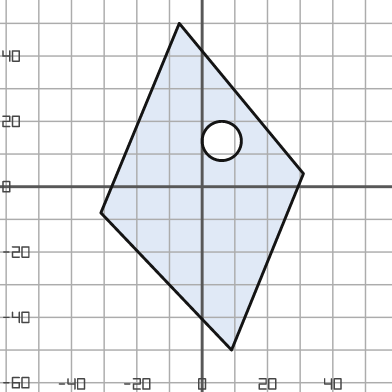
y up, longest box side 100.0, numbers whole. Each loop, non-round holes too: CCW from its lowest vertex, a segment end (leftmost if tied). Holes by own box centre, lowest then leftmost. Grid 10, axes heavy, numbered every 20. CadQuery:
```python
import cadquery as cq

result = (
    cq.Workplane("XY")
    .moveTo(9.0, -50.0)
    .lineTo(31.0, 4.0)
    .lineTo(-7.0, 50.0)
    .lineTo(-31.0, -8.0)
    .close()
    .moveTo(6.0, 14.0)
    .circle(6.0)
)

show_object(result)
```